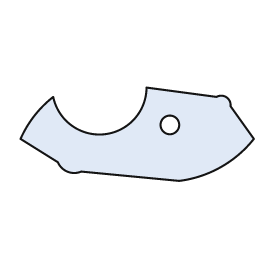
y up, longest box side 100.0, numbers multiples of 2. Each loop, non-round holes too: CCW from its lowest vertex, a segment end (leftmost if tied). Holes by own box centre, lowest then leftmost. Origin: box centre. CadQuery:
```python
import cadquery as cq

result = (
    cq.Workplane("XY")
    .moveTo(18.0, -20.0)
    .threePointArc((36.0, -14.0), (50.0, -2.0))
    .lineTo(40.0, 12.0)
    .threePointArc((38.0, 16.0), (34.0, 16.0))
    .lineTo(4.0, 20.0)
    .threePointArc((-14.0, 0.0), (-36.0, 16.0))
    .threePointArc((-44.0, 8.0), (-50.0, -2.0))
    .lineTo(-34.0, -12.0)
    .threePointArc((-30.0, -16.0), (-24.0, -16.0))
    .close()
    .moveTo(14.0, 4.0)
    .circle(4.0)
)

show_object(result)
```